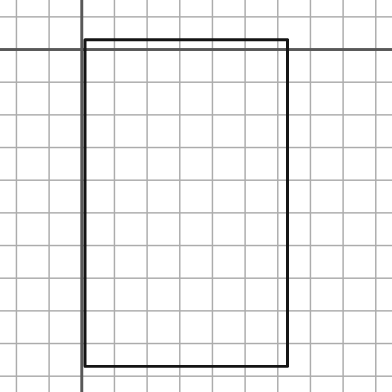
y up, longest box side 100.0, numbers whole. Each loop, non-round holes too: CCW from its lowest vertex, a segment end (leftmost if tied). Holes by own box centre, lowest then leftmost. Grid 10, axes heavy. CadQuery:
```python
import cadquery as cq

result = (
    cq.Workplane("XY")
    .moveTo(1.0, -97.0)
    .lineTo(63.0, -97.0)
    .lineTo(63.0, 3.0)
    .lineTo(1.0, 3.0)
    .close()
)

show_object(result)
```